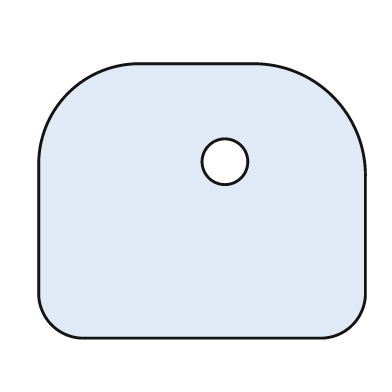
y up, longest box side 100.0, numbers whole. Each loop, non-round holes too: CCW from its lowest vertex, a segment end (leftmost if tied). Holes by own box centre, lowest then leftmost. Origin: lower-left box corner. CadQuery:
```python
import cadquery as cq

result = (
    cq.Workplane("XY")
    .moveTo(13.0, 0.0)
    .lineTo(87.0, 0.0)
    .threePointArc((96.0, 4.0), (100.0, 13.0))
    .lineTo(100.0, 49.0)
    .threePointArc((90.0, 74.0), (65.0, 84.0))
    .lineTo(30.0, 84.0)
    .threePointArc((9.0, 75.0), (0.0, 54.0))
    .lineTo(0.0, 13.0)
    .threePointArc((4.0, 4.0), (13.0, 0.0))
    .close()
    .moveTo(57.0, 54.0)
    .circle(7.0)
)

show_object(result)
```